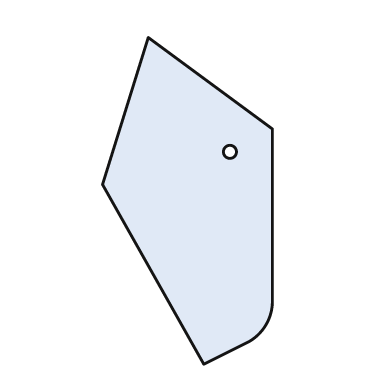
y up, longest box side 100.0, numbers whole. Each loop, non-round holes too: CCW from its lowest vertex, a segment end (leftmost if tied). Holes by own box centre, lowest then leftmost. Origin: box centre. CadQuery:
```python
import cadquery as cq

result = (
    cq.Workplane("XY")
    .moveTo(5.0, -50.0)
    .lineTo(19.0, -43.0)
    .threePointArc((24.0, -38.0), (26.0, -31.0))
    .lineTo(26.0, 22.0)
    .lineTo(-12.0, 50.0)
    .lineTo(-26.0, 5.0)
    .close()
    .moveTo(13.0, 15.0)
    .circle(2.0)
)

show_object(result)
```